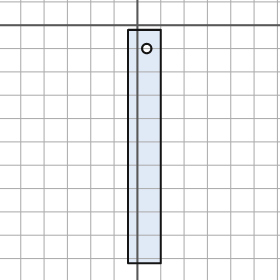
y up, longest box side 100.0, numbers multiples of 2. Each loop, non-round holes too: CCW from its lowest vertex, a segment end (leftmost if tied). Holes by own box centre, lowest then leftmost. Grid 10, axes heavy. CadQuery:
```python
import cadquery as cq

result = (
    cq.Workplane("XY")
    .moveTo(-4.0, -102.0)
    .lineTo(10.0, -102.0)
    .lineTo(10.0, -2.0)
    .lineTo(-4.0, -2.0)
    .close()
    .moveTo(4.0, -10.0)
    .circle(2.0)
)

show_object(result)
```